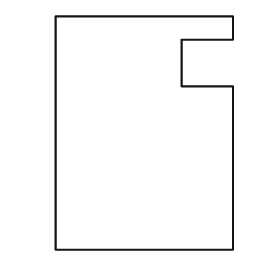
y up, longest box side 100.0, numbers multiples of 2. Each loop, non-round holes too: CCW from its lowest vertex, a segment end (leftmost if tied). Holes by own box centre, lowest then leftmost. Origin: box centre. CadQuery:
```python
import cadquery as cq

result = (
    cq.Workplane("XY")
    .moveTo(-38.0, -50.0)
    .lineTo(38.0, -50.0)
    .lineTo(38.0, 20.0)
    .lineTo(16.0, 20.0)
    .lineTo(16.0, 40.0)
    .lineTo(38.0, 40.0)
    .lineTo(38.0, 50.0)
    .lineTo(-38.0, 50.0)
    .close()
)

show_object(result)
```